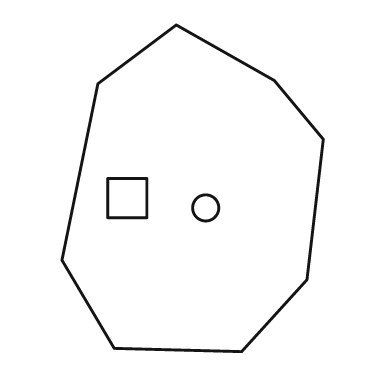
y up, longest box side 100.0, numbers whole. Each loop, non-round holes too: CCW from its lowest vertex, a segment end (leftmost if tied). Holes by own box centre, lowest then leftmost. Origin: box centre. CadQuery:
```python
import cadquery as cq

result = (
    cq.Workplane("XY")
    .moveTo(15.0, -50.0)
    .lineTo(35.0, -28.0)
    .lineTo(40.0, 15.0)
    .lineTo(25.0, 33.0)
    .lineTo(-5.0, 50.0)
    .lineTo(-29.0, 32.0)
    .lineTo(-40.0, -22.0)
    .lineTo(-24.0, -49.0)
    .close()
    .moveTo(4.0, -6.0)
    .circle(4.0)
    .moveTo(-26.0, -9.0)
    .lineTo(-14.0, -9.0)
    .lineTo(-14.0, 3.0)
    .lineTo(-26.0, 3.0)
    .close()
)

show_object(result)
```